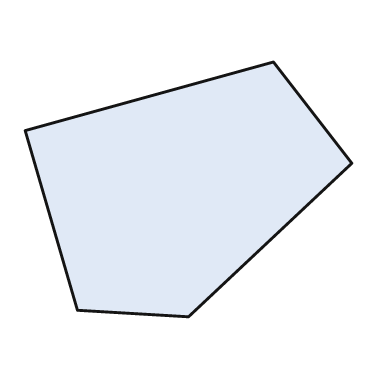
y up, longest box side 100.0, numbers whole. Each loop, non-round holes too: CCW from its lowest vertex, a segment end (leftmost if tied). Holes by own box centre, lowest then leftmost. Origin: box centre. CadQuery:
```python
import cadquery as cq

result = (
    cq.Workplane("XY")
    .moveTo(0.0, -39.0)
    .lineTo(50.0, 8.0)
    .lineTo(26.0, 39.0)
    .lineTo(-50.0, 18.0)
    .lineTo(-34.0, -37.0)
    .close()
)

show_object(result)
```